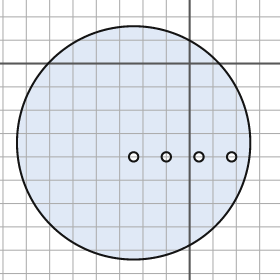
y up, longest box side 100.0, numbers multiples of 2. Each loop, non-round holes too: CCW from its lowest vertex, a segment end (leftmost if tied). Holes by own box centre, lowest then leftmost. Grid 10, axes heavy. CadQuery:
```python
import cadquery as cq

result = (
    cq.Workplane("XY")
    .moveTo(-24.0, -34.0)
    .circle(50.0)
    .moveTo(-24.0, -40.0)
    .circle(2.0)
    .moveTo(-10.0, -40.0)
    .circle(2.0)
    .moveTo(4.0, -40.0)
    .circle(2.0)
    .moveTo(18.0, -40.0)
    .circle(2.0)
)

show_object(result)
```